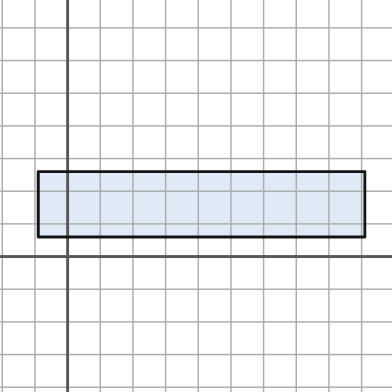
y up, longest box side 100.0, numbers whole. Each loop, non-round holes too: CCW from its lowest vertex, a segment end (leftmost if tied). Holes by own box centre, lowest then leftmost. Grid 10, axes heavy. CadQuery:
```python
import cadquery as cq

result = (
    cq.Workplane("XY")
    .moveTo(-9.0, 6.0)
    .lineTo(91.0, 6.0)
    .lineTo(91.0, 26.0)
    .lineTo(-9.0, 26.0)
    .close()
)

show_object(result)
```